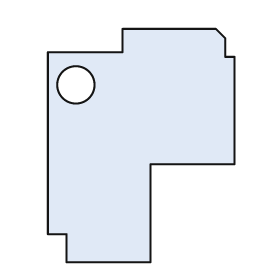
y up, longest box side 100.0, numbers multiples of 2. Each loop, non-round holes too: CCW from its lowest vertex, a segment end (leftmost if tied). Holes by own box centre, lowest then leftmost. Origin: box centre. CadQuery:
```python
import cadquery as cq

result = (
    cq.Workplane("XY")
    .moveTo(-32.0, -50.0)
    .lineTo(4.0, -50.0)
    .lineTo(4.0, -8.0)
    .lineTo(40.0, -8.0)
    .lineTo(40.0, 38.0)
    .lineTo(36.0, 38.0)
    .lineTo(36.0, 46.0)
    .lineTo(32.0, 50.0)
    .lineTo(-8.0, 50.0)
    .lineTo(-8.0, 40.0)
    .lineTo(-40.0, 40.0)
    .lineTo(-40.0, -38.0)
    .lineTo(-32.0, -38.0)
    .close()
    .moveTo(-28.0, 26.0)
    .circle(8.0)
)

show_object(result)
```